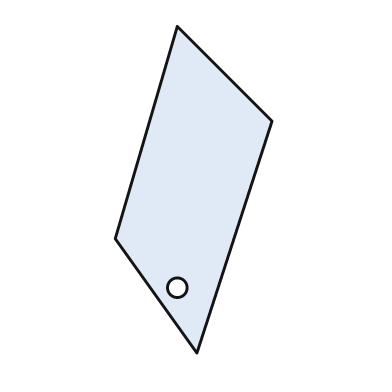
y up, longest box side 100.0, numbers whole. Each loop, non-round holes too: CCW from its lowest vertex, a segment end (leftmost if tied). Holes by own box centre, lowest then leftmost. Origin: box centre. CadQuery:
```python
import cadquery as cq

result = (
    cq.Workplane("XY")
    .moveTo(1.0, -50.0)
    .lineTo(24.0, 21.0)
    .lineTo(-5.0, 50.0)
    .lineTo(-24.0, -15.0)
    .close()
    .moveTo(-5.0, -30.0)
    .circle(3.0)
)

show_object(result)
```